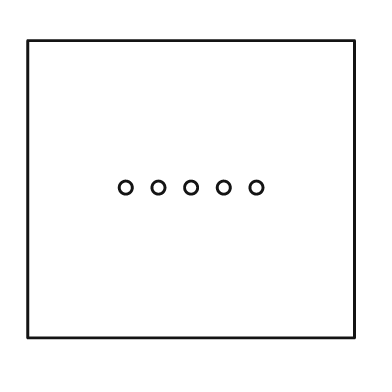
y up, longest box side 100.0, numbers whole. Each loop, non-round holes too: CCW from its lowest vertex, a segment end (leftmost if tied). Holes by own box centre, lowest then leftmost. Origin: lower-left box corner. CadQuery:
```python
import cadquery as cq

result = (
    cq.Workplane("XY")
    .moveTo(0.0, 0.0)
    .lineTo(100.0, 0.0)
    .lineTo(100.0, 91.0)
    .lineTo(0.0, 91.0)
    .close()
    .moveTo(30.0, 46.0)
    .circle(2.0)
    .moveTo(40.0, 46.0)
    .circle(2.0)
    .moveTo(50.0, 46.0)
    .circle(2.0)
    .moveTo(60.0, 46.0)
    .circle(2.0)
    .moveTo(70.0, 46.0)
    .circle(2.0)
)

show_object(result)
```